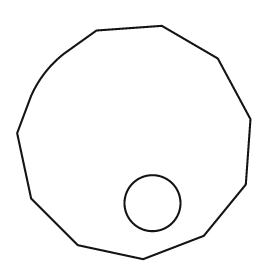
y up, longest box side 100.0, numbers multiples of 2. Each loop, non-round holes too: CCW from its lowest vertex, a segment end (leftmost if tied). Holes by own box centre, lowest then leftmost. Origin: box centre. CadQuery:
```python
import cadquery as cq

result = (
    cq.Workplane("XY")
    .moveTo(4.0, -50.0)
    .lineTo(30.0, -40.0)
    .lineTo(48.0, -18.0)
    .lineTo(50.0, 10.0)
    .lineTo(36.0, 36.0)
    .lineTo(12.0, 50.0)
    .lineTo(-16.0, 48.0)
    .lineTo(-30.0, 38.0)
    .threePointArc((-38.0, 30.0), (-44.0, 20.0))
    .lineTo(-50.0, 4.0)
    .lineTo(-44.0, -24.0)
    .lineTo(-24.0, -44.0)
    .close()
    .moveTo(8.0, -26.0)
    .circle(12.0)
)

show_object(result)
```